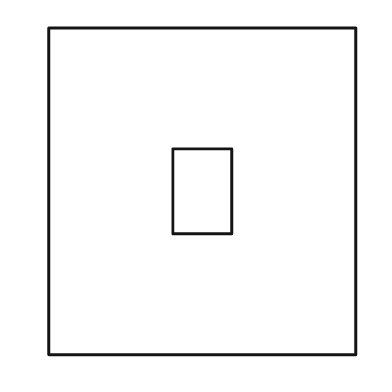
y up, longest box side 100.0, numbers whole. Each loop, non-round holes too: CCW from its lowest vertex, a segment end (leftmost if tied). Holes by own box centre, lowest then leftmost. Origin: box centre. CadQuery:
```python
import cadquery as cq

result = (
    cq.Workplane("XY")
    .moveTo(-47.0, -50.0)
    .lineTo(47.0, -50.0)
    .lineTo(47.0, 50.0)
    .lineTo(-47.0, 50.0)
    .close()
    .moveTo(-9.0, -13.0)
    .lineTo(9.0, -13.0)
    .lineTo(9.0, 13.0)
    .lineTo(-9.0, 13.0)
    .close()
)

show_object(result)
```